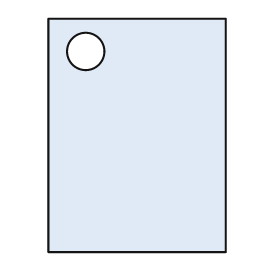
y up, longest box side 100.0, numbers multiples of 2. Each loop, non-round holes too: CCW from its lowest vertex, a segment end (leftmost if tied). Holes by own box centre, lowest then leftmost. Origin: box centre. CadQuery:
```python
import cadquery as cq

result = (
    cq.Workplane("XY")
    .moveTo(-38.0, -50.0)
    .lineTo(38.0, -50.0)
    .lineTo(38.0, 50.0)
    .lineTo(-38.0, 50.0)
    .close()
    .moveTo(-22.0, 36.0)
    .circle(8.0)
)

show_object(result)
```